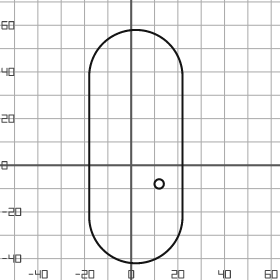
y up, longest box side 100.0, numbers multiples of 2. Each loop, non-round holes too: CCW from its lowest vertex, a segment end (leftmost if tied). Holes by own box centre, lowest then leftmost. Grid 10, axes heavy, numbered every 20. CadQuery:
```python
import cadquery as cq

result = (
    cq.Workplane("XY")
    .moveTo(-18.0, -22.0)
    .threePointArc((2.0, -42.0), (22.0, -22.0))
    .lineTo(22.0, 38.0)
    .threePointArc((2.0, 58.0), (-18.0, 38.0))
    .close()
    .moveTo(12.0, -8.0)
    .circle(2.0)
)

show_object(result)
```